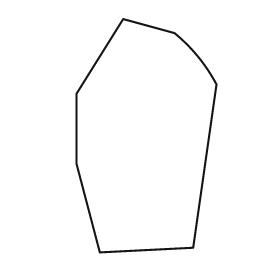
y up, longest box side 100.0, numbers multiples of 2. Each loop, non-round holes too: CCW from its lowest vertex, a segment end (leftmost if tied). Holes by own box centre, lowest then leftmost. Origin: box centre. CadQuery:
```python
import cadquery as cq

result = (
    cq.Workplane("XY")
    .moveTo(-20.0, -50.0)
    .lineTo(20.0, -48.0)
    .lineTo(30.0, 22.0)
    .threePointArc((22.0, 34.0), (12.0, 44.0))
    .lineTo(-10.0, 50.0)
    .lineTo(-30.0, 18.0)
    .lineTo(-30.0, -12.0)
    .close()
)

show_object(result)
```